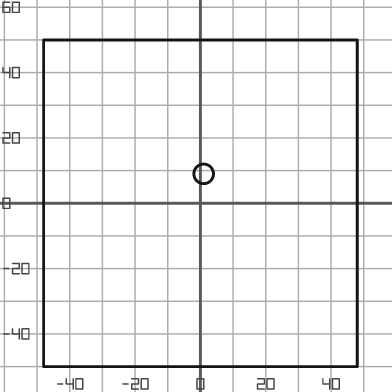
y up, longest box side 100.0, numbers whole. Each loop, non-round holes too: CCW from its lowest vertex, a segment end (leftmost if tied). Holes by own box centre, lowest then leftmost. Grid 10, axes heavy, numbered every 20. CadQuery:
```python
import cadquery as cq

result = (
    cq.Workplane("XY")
    .moveTo(-48.0, -50.0)
    .lineTo(48.0, -50.0)
    .lineTo(48.0, 50.0)
    .lineTo(-48.0, 50.0)
    .close()
    .moveTo(1.0, 9.0)
    .circle(3.0)
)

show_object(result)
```